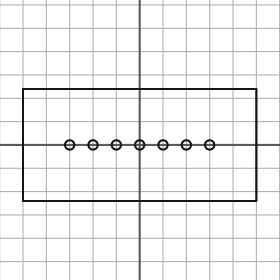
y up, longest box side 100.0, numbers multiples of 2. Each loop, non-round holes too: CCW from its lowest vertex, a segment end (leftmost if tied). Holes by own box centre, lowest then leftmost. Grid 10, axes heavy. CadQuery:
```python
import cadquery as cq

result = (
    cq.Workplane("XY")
    .moveTo(-50.0, -24.0)
    .lineTo(50.0, -24.0)
    .lineTo(50.0, 24.0)
    .lineTo(-50.0, 24.0)
    .close()
    .moveTo(-30.0, 0.0)
    .circle(2.0)
    .moveTo(-20.0, 0.0)
    .circle(2.0)
    .moveTo(-10.0, 0.0)
    .circle(2.0)
    .moveTo(0.0, 0.0)
    .circle(2.0)
    .moveTo(10.0, 0.0)
    .circle(2.0)
    .moveTo(20.0, 0.0)
    .circle(2.0)
    .moveTo(30.0, 0.0)
    .circle(2.0)
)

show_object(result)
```